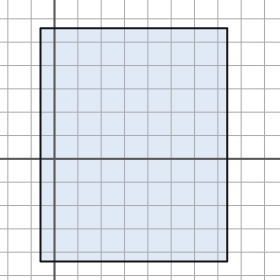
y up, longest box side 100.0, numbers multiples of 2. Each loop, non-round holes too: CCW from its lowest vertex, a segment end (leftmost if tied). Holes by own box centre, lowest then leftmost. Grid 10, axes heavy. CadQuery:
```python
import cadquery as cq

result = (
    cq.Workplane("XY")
    .moveTo(-6.0, -44.0)
    .lineTo(74.0, -44.0)
    .lineTo(74.0, 56.0)
    .lineTo(-6.0, 56.0)
    .close()
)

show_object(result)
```